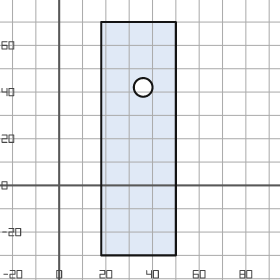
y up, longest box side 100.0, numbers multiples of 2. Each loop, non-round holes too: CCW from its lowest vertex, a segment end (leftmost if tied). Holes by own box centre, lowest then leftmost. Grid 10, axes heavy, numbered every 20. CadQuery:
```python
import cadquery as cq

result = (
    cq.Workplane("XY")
    .moveTo(18.0, -30.0)
    .lineTo(50.0, -30.0)
    .lineTo(50.0, 70.0)
    .lineTo(18.0, 70.0)
    .close()
    .moveTo(36.0, 42.0)
    .circle(4.0)
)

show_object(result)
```